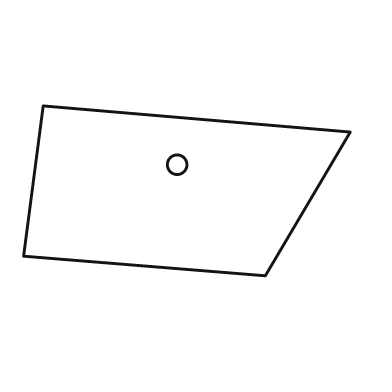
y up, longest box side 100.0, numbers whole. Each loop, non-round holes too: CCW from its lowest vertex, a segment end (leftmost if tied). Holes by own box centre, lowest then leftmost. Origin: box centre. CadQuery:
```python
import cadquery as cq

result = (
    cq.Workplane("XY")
    .moveTo(24.0, -26.0)
    .lineTo(50.0, 18.0)
    .lineTo(-44.0, 26.0)
    .lineTo(-50.0, -20.0)
    .close()
    .moveTo(-3.0, 8.0)
    .circle(3.0)
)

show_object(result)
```